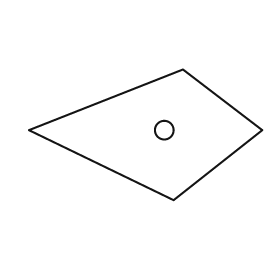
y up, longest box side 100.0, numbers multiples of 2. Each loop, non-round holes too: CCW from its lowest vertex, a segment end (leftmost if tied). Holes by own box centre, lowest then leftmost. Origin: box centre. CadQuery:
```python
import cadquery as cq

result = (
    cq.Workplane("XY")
    .moveTo(12.0, -28.0)
    .lineTo(50.0, 2.0)
    .lineTo(16.0, 28.0)
    .lineTo(-50.0, 2.0)
    .close()
    .moveTo(8.0, 2.0)
    .circle(4.0)
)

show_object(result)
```